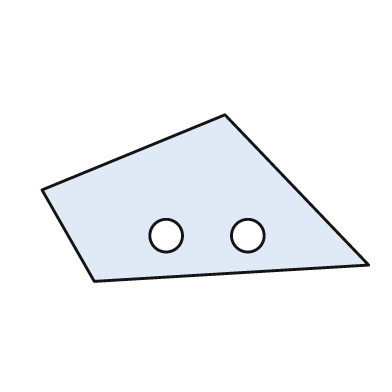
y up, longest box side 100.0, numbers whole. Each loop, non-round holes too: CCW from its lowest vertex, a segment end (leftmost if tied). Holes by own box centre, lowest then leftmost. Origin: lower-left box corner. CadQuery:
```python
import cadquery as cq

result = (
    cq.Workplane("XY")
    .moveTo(16.0, 0.0)
    .lineTo(100.0, 5.0)
    .lineTo(56.0, 51.0)
    .lineTo(0.0, 28.0)
    .close()
    .moveTo(38.0, 14.0)
    .circle(5.0)
    .moveTo(63.0, 14.0)
    .circle(5.0)
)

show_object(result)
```